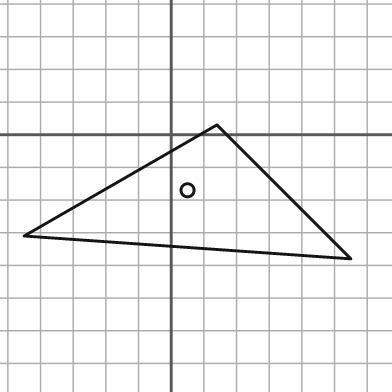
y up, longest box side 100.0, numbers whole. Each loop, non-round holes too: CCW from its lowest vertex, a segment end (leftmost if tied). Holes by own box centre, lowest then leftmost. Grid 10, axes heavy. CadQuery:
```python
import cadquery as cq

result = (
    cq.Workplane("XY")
    .moveTo(55.0, -38.0)
    .lineTo(14.0, 3.0)
    .lineTo(-45.0, -31.0)
    .close()
    .moveTo(5.0, -17.0)
    .circle(2.0)
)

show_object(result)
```